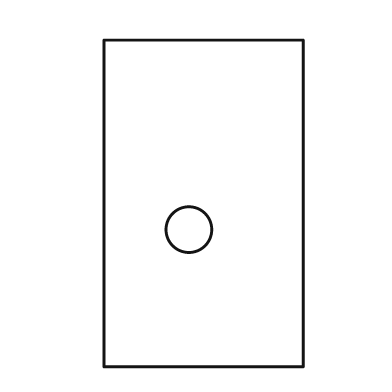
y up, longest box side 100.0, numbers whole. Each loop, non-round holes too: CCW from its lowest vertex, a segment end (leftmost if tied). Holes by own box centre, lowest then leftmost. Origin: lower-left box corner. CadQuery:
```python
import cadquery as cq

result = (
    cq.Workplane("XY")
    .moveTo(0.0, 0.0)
    .lineTo(61.0, 0.0)
    .lineTo(61.0, 100.0)
    .lineTo(0.0, 100.0)
    .close()
    .moveTo(26.0, 42.0)
    .circle(7.0)
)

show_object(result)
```